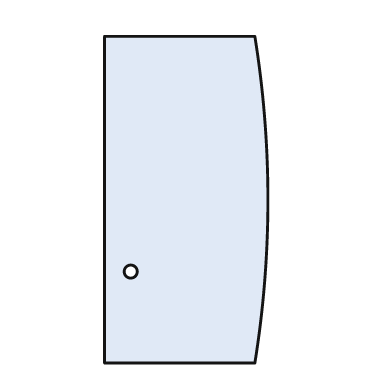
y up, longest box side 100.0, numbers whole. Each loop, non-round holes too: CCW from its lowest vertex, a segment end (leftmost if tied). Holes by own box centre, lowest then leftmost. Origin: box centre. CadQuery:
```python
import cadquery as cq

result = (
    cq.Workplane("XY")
    .moveTo(-25.0, -50.0)
    .lineTo(21.0, -50.0)
    .threePointArc((25.0, 0.0), (21.0, 50.0))
    .lineTo(-25.0, 50.0)
    .close()
    .moveTo(-17.0, -22.0)
    .circle(2.0)
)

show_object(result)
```